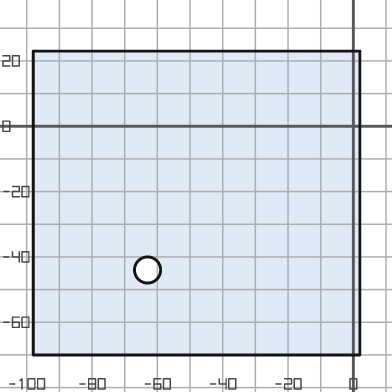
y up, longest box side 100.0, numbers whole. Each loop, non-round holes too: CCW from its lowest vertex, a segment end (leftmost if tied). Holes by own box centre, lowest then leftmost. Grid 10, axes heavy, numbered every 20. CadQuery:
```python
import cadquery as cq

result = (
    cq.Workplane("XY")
    .moveTo(-98.0, -70.0)
    .lineTo(2.0, -70.0)
    .lineTo(2.0, 23.0)
    .lineTo(-98.0, 23.0)
    .close()
    .moveTo(-63.0, -44.0)
    .circle(4.0)
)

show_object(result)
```